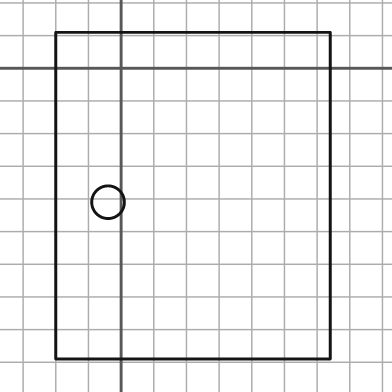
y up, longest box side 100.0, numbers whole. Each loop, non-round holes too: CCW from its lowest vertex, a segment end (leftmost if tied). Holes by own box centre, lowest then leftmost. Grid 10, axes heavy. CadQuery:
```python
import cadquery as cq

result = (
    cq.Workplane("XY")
    .moveTo(-20.0, -89.0)
    .lineTo(64.0, -89.0)
    .lineTo(64.0, 11.0)
    .lineTo(-20.0, 11.0)
    .close()
    .moveTo(-4.0, -41.0)
    .circle(5.0)
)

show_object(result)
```